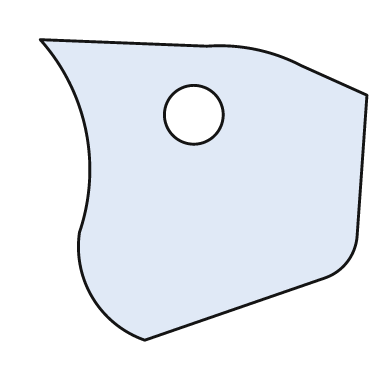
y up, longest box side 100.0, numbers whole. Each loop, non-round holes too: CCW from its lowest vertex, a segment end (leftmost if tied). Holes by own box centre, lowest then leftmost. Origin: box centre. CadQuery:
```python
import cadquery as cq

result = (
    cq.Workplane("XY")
    .moveTo(-18.0, -46.0)
    .lineTo(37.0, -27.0)
    .threePointArc((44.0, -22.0), (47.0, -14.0))
    .lineTo(50.0, 29.0)
    .lineTo(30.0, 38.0)
    .threePointArc((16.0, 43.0), (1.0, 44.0))
    .lineTo(-50.0, 46.0)
    .threePointArc((-36.0, 18.0), (-38.0, -13.0))
    .threePointArc((-34.0, -33.0), (-18.0, -46.0))
    .close()
    .moveTo(-3.0, 23.0)
    .circle(9.0)
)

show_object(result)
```